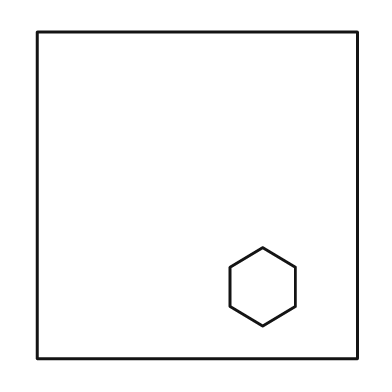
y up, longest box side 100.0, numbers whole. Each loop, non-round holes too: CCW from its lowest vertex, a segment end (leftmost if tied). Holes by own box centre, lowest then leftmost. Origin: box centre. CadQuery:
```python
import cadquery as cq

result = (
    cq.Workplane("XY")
    .moveTo(-49.0, -50.0)
    .lineTo(49.0, -50.0)
    .lineTo(49.0, 50.0)
    .lineTo(-49.0, 50.0)
    .close()
    .moveTo(20.0, -40.0)
    .lineTo(30.0, -34.0)
    .lineTo(30.0, -22.0)
    .lineTo(20.0, -16.0)
    .lineTo(10.0, -22.0)
    .lineTo(10.0, -34.0)
    .close()
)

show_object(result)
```